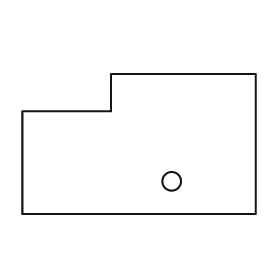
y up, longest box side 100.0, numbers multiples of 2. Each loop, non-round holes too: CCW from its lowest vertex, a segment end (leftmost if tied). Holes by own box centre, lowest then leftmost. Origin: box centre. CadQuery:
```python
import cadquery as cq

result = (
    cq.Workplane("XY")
    .moveTo(-50.0, -30.0)
    .lineTo(50.0, -30.0)
    .lineTo(50.0, 30.0)
    .lineTo(-12.0, 30.0)
    .lineTo(-12.0, 14.0)
    .lineTo(-50.0, 14.0)
    .close()
    .moveTo(14.0, -16.0)
    .circle(4.0)
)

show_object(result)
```